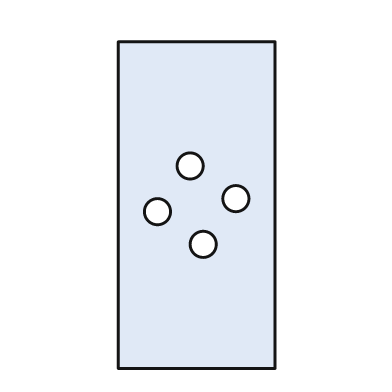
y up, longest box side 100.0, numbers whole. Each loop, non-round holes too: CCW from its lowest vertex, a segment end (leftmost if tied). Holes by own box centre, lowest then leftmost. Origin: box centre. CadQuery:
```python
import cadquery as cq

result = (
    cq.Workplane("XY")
    .moveTo(-24.0, -50.0)
    .lineTo(24.0, -50.0)
    .lineTo(24.0, 50.0)
    .lineTo(-24.0, 50.0)
    .close()
    .moveTo(2.0, -12.0)
    .circle(4.0)
    .moveTo(-12.0, -2.0)
    .circle(4.0)
    .moveTo(12.0, 2.0)
    .circle(4.0)
    .moveTo(-2.0, 12.0)
    .circle(4.0)
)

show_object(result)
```